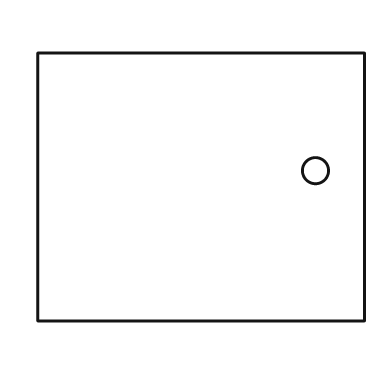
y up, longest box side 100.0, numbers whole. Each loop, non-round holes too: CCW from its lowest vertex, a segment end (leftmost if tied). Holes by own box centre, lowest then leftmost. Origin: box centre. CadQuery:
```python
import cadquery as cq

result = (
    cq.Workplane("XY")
    .moveTo(-50.0, -41.0)
    .lineTo(50.0, -41.0)
    .lineTo(50.0, 41.0)
    .lineTo(-50.0, 41.0)
    .close()
    .moveTo(35.0, 5.0)
    .circle(4.0)
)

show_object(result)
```